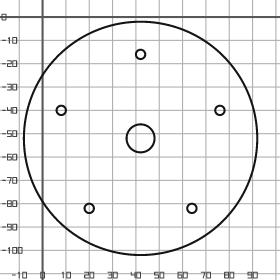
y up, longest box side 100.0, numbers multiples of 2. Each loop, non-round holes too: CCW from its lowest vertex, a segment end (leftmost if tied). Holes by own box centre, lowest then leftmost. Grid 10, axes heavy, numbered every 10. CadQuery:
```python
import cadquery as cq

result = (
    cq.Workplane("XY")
    .moveTo(42.0, -52.0)
    .circle(50.0)
    .moveTo(20.0, -82.0)
    .circle(2.0)
    .moveTo(64.0, -82.0)
    .circle(2.0)
    .moveTo(42.0, -52.0)
    .circle(6.0)
    .moveTo(8.0, -40.0)
    .circle(2.0)
    .moveTo(76.0, -40.0)
    .circle(2.0)
    .moveTo(42.0, -16.0)
    .circle(2.0)
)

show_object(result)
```